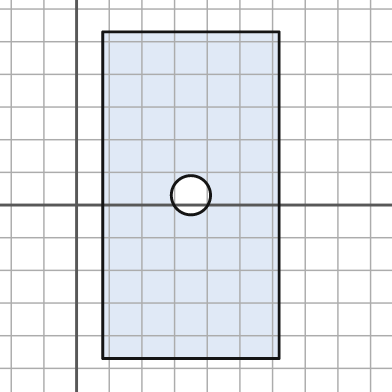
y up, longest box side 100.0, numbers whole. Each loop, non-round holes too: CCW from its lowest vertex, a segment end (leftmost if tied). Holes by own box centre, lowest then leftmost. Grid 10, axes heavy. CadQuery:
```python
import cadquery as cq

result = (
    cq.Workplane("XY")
    .moveTo(8.0, -47.0)
    .lineTo(62.0, -47.0)
    .lineTo(62.0, 53.0)
    .lineTo(8.0, 53.0)
    .close()
    .moveTo(35.0, 3.0)
    .circle(6.0)
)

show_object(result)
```